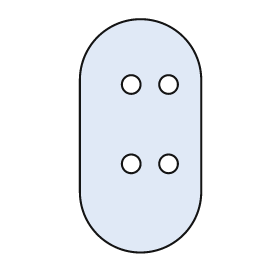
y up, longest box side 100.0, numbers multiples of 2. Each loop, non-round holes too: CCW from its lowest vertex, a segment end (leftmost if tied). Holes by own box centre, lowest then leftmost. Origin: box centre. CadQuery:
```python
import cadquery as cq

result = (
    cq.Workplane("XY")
    .moveTo(-26.0, -24.0)
    .threePointArc((0.0, -50.0), (26.0, -24.0))
    .lineTo(26.0, 24.0)
    .threePointArc((0.0, 50.0), (-26.0, 24.0))
    .close()
    .moveTo(-4.0, -12.0)
    .circle(4.0)
    .moveTo(12.0, -12.0)
    .circle(4.0)
    .moveTo(-4.0, 22.0)
    .circle(4.0)
    .moveTo(12.0, 22.0)
    .circle(4.0)
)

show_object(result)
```